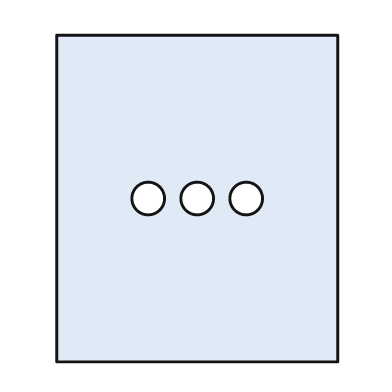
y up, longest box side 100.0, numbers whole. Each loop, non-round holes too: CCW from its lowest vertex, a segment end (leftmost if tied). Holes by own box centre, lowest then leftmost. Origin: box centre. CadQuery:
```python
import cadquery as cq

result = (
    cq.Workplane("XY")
    .moveTo(-43.0, -50.0)
    .lineTo(43.0, -50.0)
    .lineTo(43.0, 50.0)
    .lineTo(-43.0, 50.0)
    .close()
    .moveTo(-15.0, 0.0)
    .circle(5.0)
    .moveTo(0.0, 0.0)
    .circle(5.0)
    .moveTo(15.0, 0.0)
    .circle(5.0)
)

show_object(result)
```